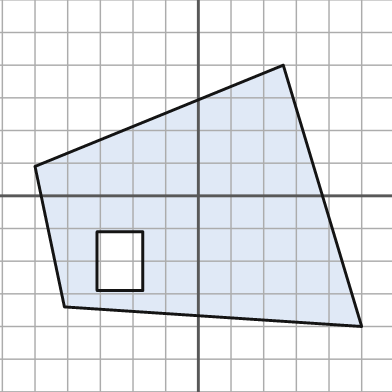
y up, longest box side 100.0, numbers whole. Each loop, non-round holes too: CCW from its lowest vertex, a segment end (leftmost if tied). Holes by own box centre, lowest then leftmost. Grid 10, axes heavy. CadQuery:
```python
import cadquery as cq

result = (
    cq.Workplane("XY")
    .moveTo(50.0, -40.0)
    .lineTo(26.0, 40.0)
    .lineTo(-50.0, 9.0)
    .lineTo(-41.0, -34.0)
    .close()
    .moveTo(-31.0, -29.0)
    .lineTo(-17.0, -29.0)
    .lineTo(-17.0, -11.0)
    .lineTo(-31.0, -11.0)
    .close()
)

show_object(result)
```